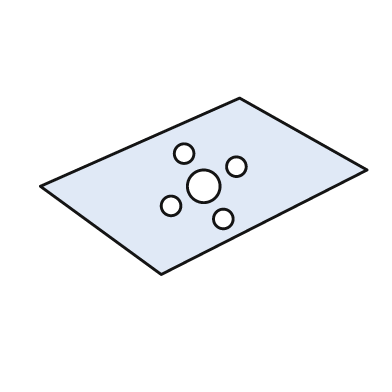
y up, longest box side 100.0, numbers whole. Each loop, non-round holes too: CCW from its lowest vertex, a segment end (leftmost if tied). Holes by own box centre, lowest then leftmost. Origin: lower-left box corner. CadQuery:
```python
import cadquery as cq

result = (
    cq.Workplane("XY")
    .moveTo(37.0, 0.0)
    .lineTo(100.0, 32.0)
    .lineTo(61.0, 54.0)
    .lineTo(0.0, 27.0)
    .close()
    .moveTo(56.0, 17.0)
    .circle(3.0)
    .moveTo(40.0, 21.0)
    .circle(3.0)
    .moveTo(50.0, 27.0)
    .circle(5.0)
    .moveTo(60.0, 33.0)
    .circle(3.0)
    .moveTo(44.0, 37.0)
    .circle(3.0)
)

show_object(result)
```